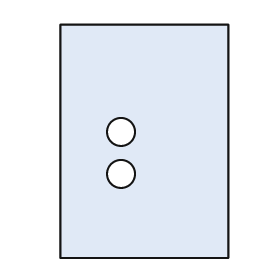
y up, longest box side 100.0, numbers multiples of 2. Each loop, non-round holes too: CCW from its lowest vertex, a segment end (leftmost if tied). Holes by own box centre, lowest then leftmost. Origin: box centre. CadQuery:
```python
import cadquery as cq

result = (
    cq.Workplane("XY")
    .moveTo(-36.0, -50.0)
    .lineTo(36.0, -50.0)
    .lineTo(36.0, 50.0)
    .lineTo(-36.0, 50.0)
    .close()
    .moveTo(-10.0, -14.0)
    .circle(6.0)
    .moveTo(-10.0, 4.0)
    .circle(6.0)
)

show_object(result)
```